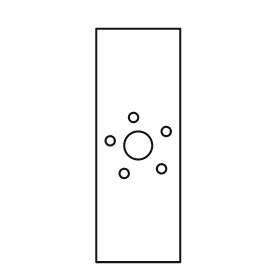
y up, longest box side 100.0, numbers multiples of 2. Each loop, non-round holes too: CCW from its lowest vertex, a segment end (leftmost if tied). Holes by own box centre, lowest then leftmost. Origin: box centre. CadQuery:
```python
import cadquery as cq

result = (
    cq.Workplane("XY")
    .moveTo(-18.0, -50.0)
    .lineTo(18.0, -50.0)
    .lineTo(18.0, 50.0)
    .lineTo(-18.0, 50.0)
    .close()
    .moveTo(-6.0, -12.0)
    .circle(2.0)
    .moveTo(10.0, -10.0)
    .circle(2.0)
    .moveTo(0.0, 0.0)
    .circle(6.0)
    .moveTo(-12.0, 2.0)
    .circle(2.0)
    .moveTo(12.0, 6.0)
    .circle(2.0)
    .moveTo(-2.0, 12.0)
    .circle(2.0)
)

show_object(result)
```